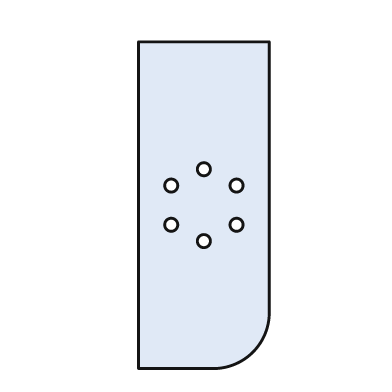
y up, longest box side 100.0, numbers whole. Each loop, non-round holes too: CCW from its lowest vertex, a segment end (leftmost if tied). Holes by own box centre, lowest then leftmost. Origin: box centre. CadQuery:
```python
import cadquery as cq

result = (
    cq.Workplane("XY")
    .moveTo(-20.0, -50.0)
    .lineTo(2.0, -50.0)
    .threePointArc((15.0, -45.0), (20.0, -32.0))
    .lineTo(20.0, 50.0)
    .lineTo(-20.0, 50.0)
    .close()
    .moveTo(0.0, -11.0)
    .circle(2.0)
    .moveTo(-10.0, -6.0)
    .circle(2.0)
    .moveTo(10.0, -6.0)
    .circle(2.0)
    .moveTo(-10.0, 6.0)
    .circle(2.0)
    .moveTo(10.0, 6.0)
    .circle(2.0)
    .moveTo(0.0, 11.0)
    .circle(2.0)
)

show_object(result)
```